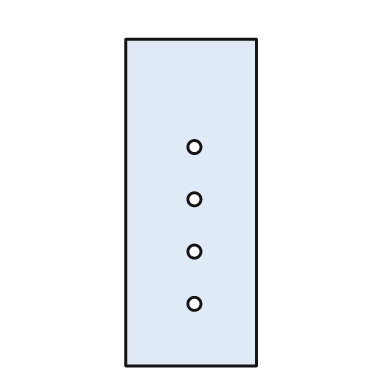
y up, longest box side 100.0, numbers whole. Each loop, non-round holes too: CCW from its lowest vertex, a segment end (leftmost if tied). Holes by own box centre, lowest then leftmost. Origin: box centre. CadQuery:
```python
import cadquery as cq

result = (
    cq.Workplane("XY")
    .moveTo(-20.0, -50.0)
    .lineTo(20.0, -50.0)
    .lineTo(20.0, 50.0)
    .lineTo(-20.0, 50.0)
    .close()
    .moveTo(1.0, -31.0)
    .circle(2.0)
    .moveTo(1.0, -15.0)
    .circle(2.0)
    .moveTo(1.0, 1.0)
    .circle(2.0)
    .moveTo(1.0, 17.0)
    .circle(2.0)
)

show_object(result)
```